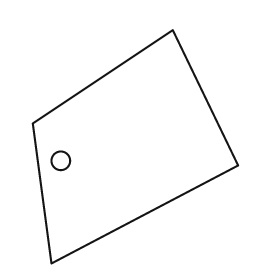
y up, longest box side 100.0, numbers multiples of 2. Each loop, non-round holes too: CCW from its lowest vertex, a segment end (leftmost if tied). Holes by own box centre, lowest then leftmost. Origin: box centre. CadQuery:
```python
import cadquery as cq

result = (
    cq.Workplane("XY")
    .moveTo(-36.0, -50.0)
    .lineTo(44.0, -8.0)
    .lineTo(16.0, 50.0)
    .lineTo(-44.0, 10.0)
    .close()
    .moveTo(-32.0, -6.0)
    .circle(4.0)
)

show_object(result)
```